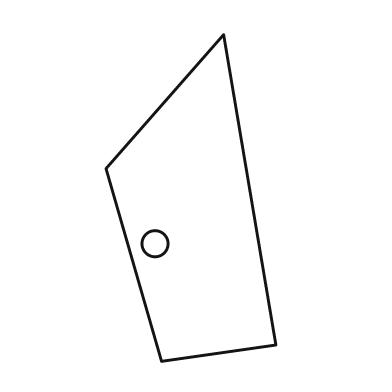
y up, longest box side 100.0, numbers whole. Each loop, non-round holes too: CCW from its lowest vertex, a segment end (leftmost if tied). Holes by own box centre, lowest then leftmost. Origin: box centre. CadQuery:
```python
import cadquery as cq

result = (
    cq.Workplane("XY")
    .moveTo(-9.0, -50.0)
    .lineTo(26.0, -45.0)
    .lineTo(10.0, 50.0)
    .lineTo(-26.0, 9.0)
    .close()
    .moveTo(-11.0, -14.0)
    .circle(4.0)
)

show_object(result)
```